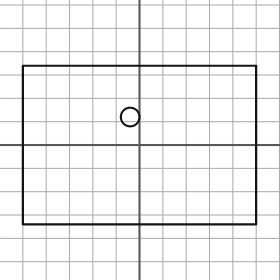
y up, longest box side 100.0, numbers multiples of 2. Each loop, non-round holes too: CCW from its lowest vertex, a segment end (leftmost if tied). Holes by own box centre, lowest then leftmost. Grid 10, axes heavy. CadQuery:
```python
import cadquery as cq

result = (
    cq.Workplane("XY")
    .moveTo(-50.0, -34.0)
    .lineTo(50.0, -34.0)
    .lineTo(50.0, 34.0)
    .lineTo(-50.0, 34.0)
    .close()
    .moveTo(-4.0, 12.0)
    .circle(4.0)
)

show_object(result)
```